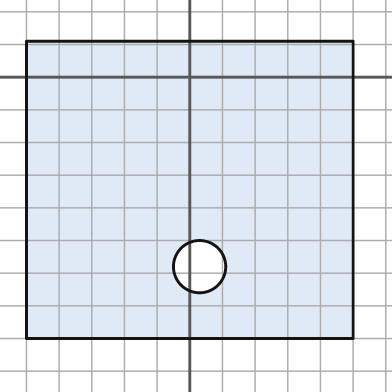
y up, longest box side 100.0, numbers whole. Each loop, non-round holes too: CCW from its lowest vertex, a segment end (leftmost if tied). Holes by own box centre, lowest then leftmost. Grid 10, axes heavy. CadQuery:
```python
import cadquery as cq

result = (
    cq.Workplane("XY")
    .moveTo(-50.0, -80.0)
    .lineTo(50.0, -80.0)
    .lineTo(50.0, 11.0)
    .lineTo(-50.0, 11.0)
    .close()
    .moveTo(3.0, -58.0)
    .circle(8.0)
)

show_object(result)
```